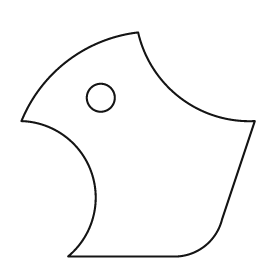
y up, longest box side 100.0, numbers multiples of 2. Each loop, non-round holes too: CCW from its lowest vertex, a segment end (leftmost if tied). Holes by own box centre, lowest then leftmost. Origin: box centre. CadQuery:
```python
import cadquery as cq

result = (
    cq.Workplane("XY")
    .moveTo(-30.0, -48.0)
    .lineTo(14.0, -48.0)
    .threePointArc((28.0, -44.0), (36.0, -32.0))
    .lineTo(50.0, 10.0)
    .threePointArc((18.0, 20.0), (0.0, 48.0))
    .threePointArc((-30.0, 36.0), (-50.0, 10.0))
    .threePointArc((-20.0, -12.0), (-30.0, -48.0))
    .close()
    .moveTo(-16.0, 20.0)
    .circle(6.0)
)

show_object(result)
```